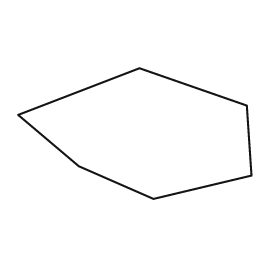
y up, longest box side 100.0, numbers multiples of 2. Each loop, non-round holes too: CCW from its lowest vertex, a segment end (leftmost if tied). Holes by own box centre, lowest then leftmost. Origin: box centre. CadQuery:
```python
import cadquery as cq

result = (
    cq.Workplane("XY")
    .moveTo(8.0, -28.0)
    .lineTo(50.0, -18.0)
    .lineTo(48.0, 12.0)
    .lineTo(2.0, 28.0)
    .lineTo(-50.0, 8.0)
    .lineTo(-24.0, -14.0)
    .close()
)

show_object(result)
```